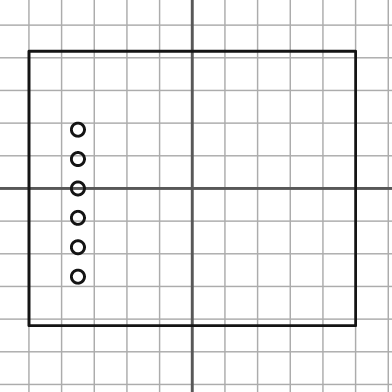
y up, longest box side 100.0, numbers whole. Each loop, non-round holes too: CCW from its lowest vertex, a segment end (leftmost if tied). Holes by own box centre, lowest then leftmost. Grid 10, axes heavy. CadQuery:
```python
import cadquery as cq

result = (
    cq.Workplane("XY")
    .moveTo(-50.0, -42.0)
    .lineTo(50.0, -42.0)
    .lineTo(50.0, 42.0)
    .lineTo(-50.0, 42.0)
    .close()
    .moveTo(-35.0, -27.0)
    .circle(2.0)
    .moveTo(-35.0, -18.0)
    .circle(2.0)
    .moveTo(-35.0, -9.0)
    .circle(2.0)
    .moveTo(-35.0, 0.0)
    .circle(2.0)
    .moveTo(-35.0, 9.0)
    .circle(2.0)
    .moveTo(-35.0, 18.0)
    .circle(2.0)
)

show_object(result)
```